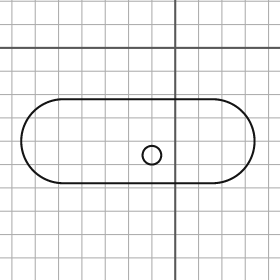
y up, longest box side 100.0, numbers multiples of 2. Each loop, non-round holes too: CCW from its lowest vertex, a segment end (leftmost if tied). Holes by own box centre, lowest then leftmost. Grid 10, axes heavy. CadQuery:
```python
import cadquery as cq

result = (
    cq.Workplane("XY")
    .moveTo(-48.0, -58.0)
    .lineTo(16.0, -58.0)
    .threePointArc((34.0, -40.0), (16.0, -22.0))
    .lineTo(-48.0, -22.0)
    .threePointArc((-66.0, -40.0), (-48.0, -58.0))
    .close()
    .moveTo(-10.0, -46.0)
    .circle(4.0)
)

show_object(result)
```